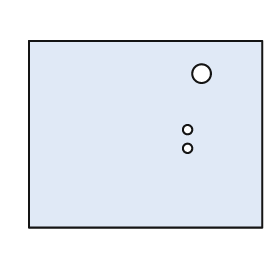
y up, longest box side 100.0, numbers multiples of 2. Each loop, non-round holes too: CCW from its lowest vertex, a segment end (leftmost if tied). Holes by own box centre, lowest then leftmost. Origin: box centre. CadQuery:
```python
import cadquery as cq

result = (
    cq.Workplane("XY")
    .moveTo(-50.0, -40.0)
    .lineTo(50.0, -40.0)
    .lineTo(50.0, 40.0)
    .lineTo(-50.0, 40.0)
    .close()
    .moveTo(18.0, -6.0)
    .circle(2.0)
    .moveTo(18.0, 2.0)
    .circle(2.0)
    .moveTo(24.0, 26.0)
    .circle(4.0)
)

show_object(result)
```